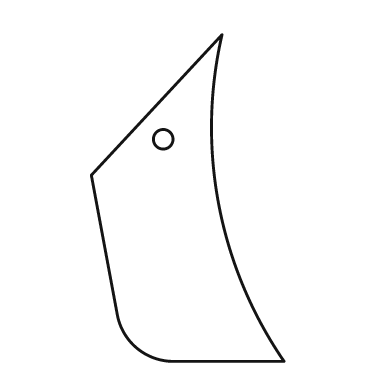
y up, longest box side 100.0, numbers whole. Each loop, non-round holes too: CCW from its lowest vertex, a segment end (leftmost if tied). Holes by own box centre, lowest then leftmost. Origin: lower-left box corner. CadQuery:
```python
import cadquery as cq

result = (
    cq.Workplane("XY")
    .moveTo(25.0, 0.0)
    .lineTo(59.0, 0.0)
    .threePointArc((39.0, 48.0), (40.0, 100.0))
    .lineTo(0.0, 57.0)
    .lineTo(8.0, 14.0)
    .threePointArc((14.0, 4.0), (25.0, 0.0))
    .close()
    .moveTo(22.0, 68.0)
    .circle(3.0)
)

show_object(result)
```